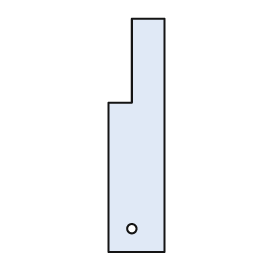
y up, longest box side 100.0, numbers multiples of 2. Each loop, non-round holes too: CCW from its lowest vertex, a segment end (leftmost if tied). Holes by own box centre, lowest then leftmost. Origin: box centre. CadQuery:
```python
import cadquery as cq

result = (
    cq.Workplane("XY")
    .moveTo(-12.0, -50.0)
    .lineTo(12.0, -50.0)
    .lineTo(12.0, 50.0)
    .lineTo(-2.0, 50.0)
    .lineTo(-2.0, 14.0)
    .lineTo(-12.0, 14.0)
    .close()
    .moveTo(-2.0, -40.0)
    .circle(2.0)
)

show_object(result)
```